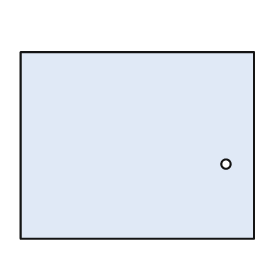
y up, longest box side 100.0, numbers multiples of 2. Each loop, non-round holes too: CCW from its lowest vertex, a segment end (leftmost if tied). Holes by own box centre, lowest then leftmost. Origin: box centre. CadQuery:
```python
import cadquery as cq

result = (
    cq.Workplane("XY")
    .moveTo(-50.0, -40.0)
    .lineTo(50.0, -40.0)
    .lineTo(50.0, 40.0)
    .lineTo(-50.0, 40.0)
    .close()
    .moveTo(38.0, -8.0)
    .circle(2.0)
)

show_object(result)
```